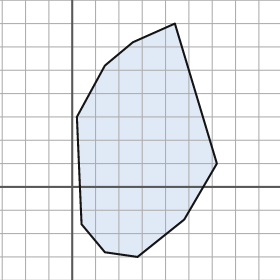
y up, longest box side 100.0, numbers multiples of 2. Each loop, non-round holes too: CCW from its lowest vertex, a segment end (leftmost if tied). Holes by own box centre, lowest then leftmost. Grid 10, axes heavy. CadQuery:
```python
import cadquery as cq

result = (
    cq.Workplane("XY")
    .moveTo(28.0, -30.0)
    .lineTo(48.0, -14.0)
    .lineTo(62.0, 10.0)
    .lineTo(44.0, 70.0)
    .lineTo(26.0, 62.0)
    .lineTo(14.0, 52.0)
    .lineTo(2.0, 30.0)
    .lineTo(4.0, -16.0)
    .lineTo(14.0, -28.0)
    .close()
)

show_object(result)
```